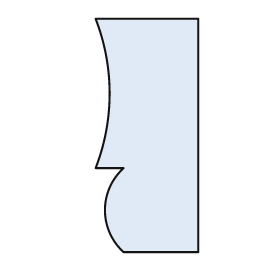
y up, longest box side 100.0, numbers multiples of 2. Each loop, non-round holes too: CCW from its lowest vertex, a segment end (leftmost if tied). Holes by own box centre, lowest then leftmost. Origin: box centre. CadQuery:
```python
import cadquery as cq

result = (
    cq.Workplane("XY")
    .moveTo(-10.0, -50.0)
    .lineTo(22.0, -50.0)
    .lineTo(22.0, 50.0)
    .lineTo(-22.0, 50.0)
    .threePointArc((-16.0, 18.0), (-22.0, -14.0))
    .lineTo(-10.0, -14.0)
    .threePointArc((-18.0, -32.0), (-10.0, -50.0))
    .close()
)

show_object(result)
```